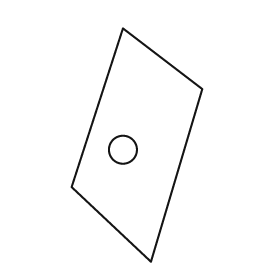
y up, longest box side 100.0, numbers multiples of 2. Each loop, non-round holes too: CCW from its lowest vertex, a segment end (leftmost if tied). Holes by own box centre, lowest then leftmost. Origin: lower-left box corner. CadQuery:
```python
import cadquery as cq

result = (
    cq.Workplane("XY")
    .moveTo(34.0, 0.0)
    .lineTo(56.0, 74.0)
    .lineTo(22.0, 100.0)
    .lineTo(0.0, 32.0)
    .close()
    .moveTo(22.0, 48.0)
    .circle(6.0)
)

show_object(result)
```